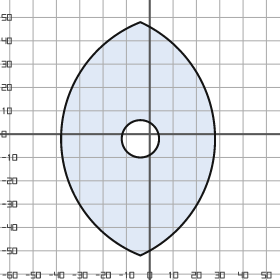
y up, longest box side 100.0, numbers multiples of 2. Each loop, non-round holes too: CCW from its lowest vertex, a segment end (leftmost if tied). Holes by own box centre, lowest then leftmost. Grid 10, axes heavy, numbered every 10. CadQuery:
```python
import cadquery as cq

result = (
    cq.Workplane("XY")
    .moveTo(-4.0, -52.0)
    .threePointArc((28.0, -2.0), (-4.0, 48.0))
    .threePointArc((-38.0, -2.0), (-4.0, -52.0))
    .close()
    .moveTo(-4.0, -2.0)
    .circle(8.0)
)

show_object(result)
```